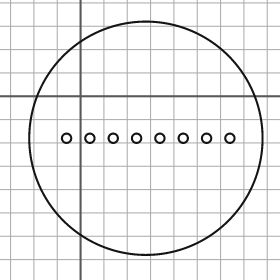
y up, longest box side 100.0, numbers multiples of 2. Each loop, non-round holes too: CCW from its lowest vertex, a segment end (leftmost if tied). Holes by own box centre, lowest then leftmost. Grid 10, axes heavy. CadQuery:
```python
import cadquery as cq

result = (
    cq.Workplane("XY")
    .moveTo(28.0, -18.0)
    .circle(50.0)
    .moveTo(-6.0, -18.0)
    .circle(2.0)
    .moveTo(4.0, -18.0)
    .circle(2.0)
    .moveTo(14.0, -18.0)
    .circle(2.0)
    .moveTo(24.0, -18.0)
    .circle(2.0)
    .moveTo(34.0, -18.0)
    .circle(2.0)
    .moveTo(44.0, -18.0)
    .circle(2.0)
    .moveTo(54.0, -18.0)
    .circle(2.0)
    .moveTo(64.0, -18.0)
    .circle(2.0)
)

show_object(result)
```